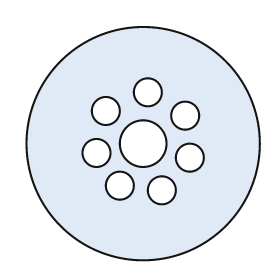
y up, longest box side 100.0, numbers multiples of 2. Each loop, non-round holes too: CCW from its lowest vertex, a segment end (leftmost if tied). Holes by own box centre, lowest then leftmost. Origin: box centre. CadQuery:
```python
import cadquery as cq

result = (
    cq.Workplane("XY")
    .moveTo(0.0, 0.0)
    .circle(50.0)
    .moveTo(8.0, -20.0)
    .circle(6.0)
    .moveTo(-10.0, -18.0)
    .circle(6.0)
    .moveTo(20.0, -6.0)
    .circle(6.0)
    .moveTo(-20.0, -4.0)
    .circle(6.0)
    .moveTo(0.0, 0.0)
    .circle(10.0)
    .moveTo(18.0, 12.0)
    .circle(6.0)
    .moveTo(-16.0, 14.0)
    .circle(6.0)
    .moveTo(2.0, 22.0)
    .circle(6.0)
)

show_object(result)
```